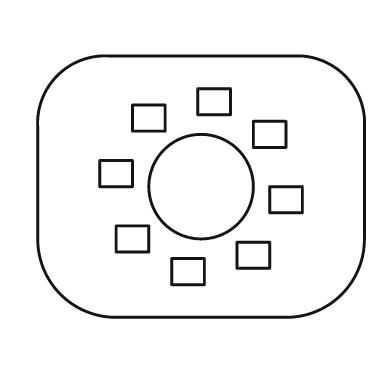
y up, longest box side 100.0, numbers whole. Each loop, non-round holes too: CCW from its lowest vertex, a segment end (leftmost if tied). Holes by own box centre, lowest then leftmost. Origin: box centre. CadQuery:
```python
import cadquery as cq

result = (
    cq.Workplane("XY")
    .moveTo(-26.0, -40.0)
    .lineTo(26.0, -40.0)
    .threePointArc((43.0, -33.0), (50.0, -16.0))
    .lineTo(50.0, 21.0)
    .threePointArc((44.0, 34.0), (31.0, 40.0))
    .lineTo(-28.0, 40.0)
    .threePointArc((-44.0, 34.0), (-50.0, 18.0))
    .lineTo(-50.0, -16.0)
    .threePointArc((-43.0, -33.0), (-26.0, -40.0))
    .close()
    .moveTo(-9.0, -30.0)
    .lineTo(1.0, -30.0)
    .lineTo(1.0, -22.0)
    .lineTo(-9.0, -22.0)
    .close()
    .moveTo(11.0, -25.0)
    .lineTo(21.0, -25.0)
    .lineTo(21.0, -17.0)
    .lineTo(11.0, -17.0)
    .close()
    .moveTo(-26.0, -20.0)
    .lineTo(-16.0, -20.0)
    .lineTo(-16.0, -12.0)
    .lineTo(-26.0, -12.0)
    .close()
    .moveTo(21.0, -8.0)
    .lineTo(31.0, -8.0)
    .lineTo(31.0, 0.0)
    .lineTo(21.0, 0.0)
    .close()
    .moveTo(0.0, 0.0)
    .circle(16.0)
    .moveTo(-31.0, 0.0)
    .lineTo(-21.0, 0.0)
    .lineTo(-21.0, 8.0)
    .lineTo(-31.0, 8.0)
    .close()
    .moveTo(16.0, 12.0)
    .lineTo(26.0, 12.0)
    .lineTo(26.0, 20.0)
    .lineTo(16.0, 20.0)
    .close()
    .moveTo(-21.0, 17.0)
    .lineTo(-11.0, 17.0)
    .lineTo(-11.0, 25.0)
    .lineTo(-21.0, 25.0)
    .close()
    .moveTo(-1.0, 22.0)
    .lineTo(9.0, 22.0)
    .lineTo(9.0, 30.0)
    .lineTo(-1.0, 30.0)
    .close()
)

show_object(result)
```